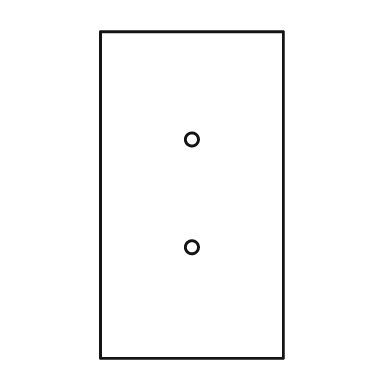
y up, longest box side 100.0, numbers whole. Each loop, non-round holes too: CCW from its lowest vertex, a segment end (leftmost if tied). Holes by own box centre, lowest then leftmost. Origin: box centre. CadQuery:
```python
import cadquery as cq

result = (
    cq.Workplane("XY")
    .moveTo(-28.0, -50.0)
    .lineTo(28.0, -50.0)
    .lineTo(28.0, 50.0)
    .lineTo(-28.0, 50.0)
    .close()
    .moveTo(0.0, -16.0)
    .circle(2.0)
    .moveTo(0.0, 17.0)
    .circle(2.0)
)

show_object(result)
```